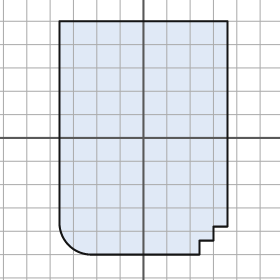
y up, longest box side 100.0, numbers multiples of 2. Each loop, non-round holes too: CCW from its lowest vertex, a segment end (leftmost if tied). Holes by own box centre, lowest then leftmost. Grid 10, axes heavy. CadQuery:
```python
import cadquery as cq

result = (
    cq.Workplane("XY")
    .moveTo(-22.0, -50.0)
    .lineTo(24.0, -50.0)
    .lineTo(24.0, -44.0)
    .lineTo(30.0, -44.0)
    .lineTo(30.0, -38.0)
    .lineTo(36.0, -38.0)
    .lineTo(36.0, 50.0)
    .lineTo(-36.0, 50.0)
    .lineTo(-36.0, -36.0)
    .threePointArc((-32.0, -46.0), (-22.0, -50.0))
    .close()
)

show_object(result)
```